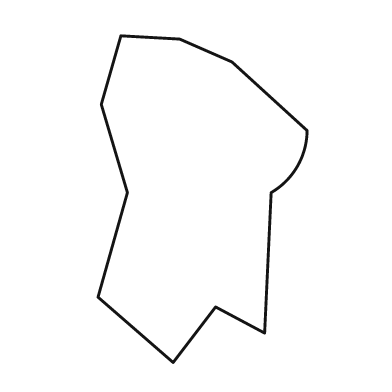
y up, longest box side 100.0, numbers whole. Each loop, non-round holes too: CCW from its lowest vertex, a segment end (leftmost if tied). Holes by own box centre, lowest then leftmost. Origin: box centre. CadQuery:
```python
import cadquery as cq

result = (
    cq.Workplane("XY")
    .moveTo(-9.0, -50.0)
    .lineTo(4.0, -33.0)
    .lineTo(19.0, -41.0)
    .lineTo(21.0, 2.0)
    .threePointArc((29.0, 10.0), (32.0, 21.0))
    .lineTo(9.0, 42.0)
    .lineTo(-7.0, 49.0)
    .lineTo(-25.0, 50.0)
    .lineTo(-31.0, 29.0)
    .lineTo(-23.0, 2.0)
    .lineTo(-32.0, -30.0)
    .close()
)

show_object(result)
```